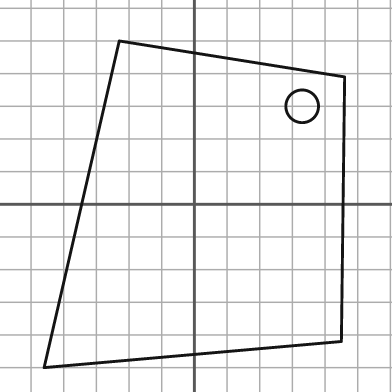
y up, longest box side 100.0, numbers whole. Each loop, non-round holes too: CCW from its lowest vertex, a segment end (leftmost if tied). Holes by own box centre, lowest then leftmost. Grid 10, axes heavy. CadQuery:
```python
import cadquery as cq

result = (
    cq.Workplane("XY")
    .moveTo(-46.0, -50.0)
    .lineTo(45.0, -42.0)
    .lineTo(46.0, 39.0)
    .lineTo(-23.0, 50.0)
    .close()
    .moveTo(33.0, 30.0)
    .circle(5.0)
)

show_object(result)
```